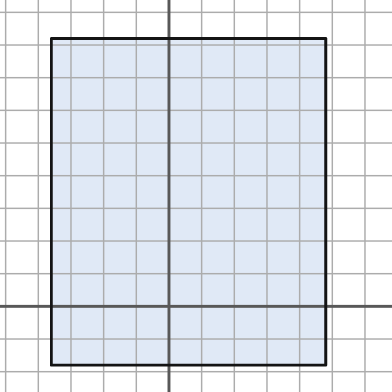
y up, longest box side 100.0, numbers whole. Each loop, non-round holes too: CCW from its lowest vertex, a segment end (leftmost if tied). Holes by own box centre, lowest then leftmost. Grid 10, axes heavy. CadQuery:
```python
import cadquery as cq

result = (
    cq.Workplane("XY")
    .moveTo(-36.0, -18.0)
    .lineTo(48.0, -18.0)
    .lineTo(48.0, 82.0)
    .lineTo(-36.0, 82.0)
    .close()
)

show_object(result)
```